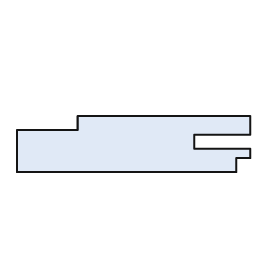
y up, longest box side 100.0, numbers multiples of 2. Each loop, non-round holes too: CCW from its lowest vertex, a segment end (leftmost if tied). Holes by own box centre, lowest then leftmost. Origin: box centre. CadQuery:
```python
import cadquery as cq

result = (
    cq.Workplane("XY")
    .moveTo(-50.0, -12.0)
    .lineTo(44.0, -12.0)
    .lineTo(44.0, -6.0)
    .lineTo(50.0, -6.0)
    .lineTo(50.0, -2.0)
    .lineTo(26.0, -2.0)
    .lineTo(26.0, 4.0)
    .lineTo(50.0, 4.0)
    .lineTo(50.0, 12.0)
    .lineTo(-24.0, 12.0)
    .lineTo(-24.0, 6.0)
    .lineTo(-50.0, 6.0)
    .close()
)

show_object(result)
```